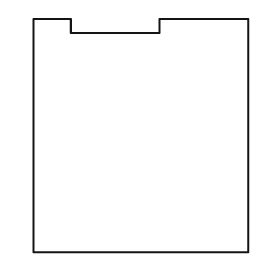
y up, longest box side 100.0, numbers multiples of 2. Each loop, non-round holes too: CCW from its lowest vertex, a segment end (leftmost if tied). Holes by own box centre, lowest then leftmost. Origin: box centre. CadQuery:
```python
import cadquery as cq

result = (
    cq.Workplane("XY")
    .moveTo(-46.0, -50.0)
    .lineTo(46.0, -50.0)
    .lineTo(46.0, 50.0)
    .lineTo(8.0, 50.0)
    .lineTo(8.0, 44.0)
    .lineTo(-30.0, 44.0)
    .lineTo(-30.0, 50.0)
    .lineTo(-46.0, 50.0)
    .close()
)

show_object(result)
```